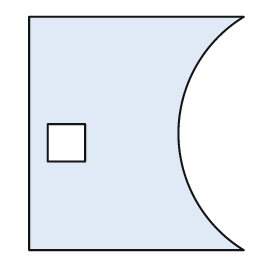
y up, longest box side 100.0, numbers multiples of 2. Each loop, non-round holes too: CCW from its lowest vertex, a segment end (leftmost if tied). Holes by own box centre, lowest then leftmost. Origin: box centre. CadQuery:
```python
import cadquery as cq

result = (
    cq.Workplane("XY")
    .moveTo(-46.0, -50.0)
    .lineTo(46.0, -50.0)
    .threePointArc((18.0, 0.0), (46.0, 50.0))
    .lineTo(-46.0, 50.0)
    .close()
    .moveTo(-38.0, -12.0)
    .lineTo(-22.0, -12.0)
    .lineTo(-22.0, 4.0)
    .lineTo(-38.0, 4.0)
    .close()
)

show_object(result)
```